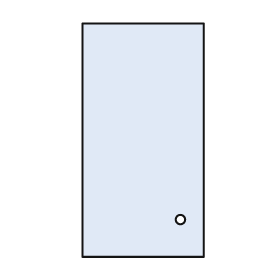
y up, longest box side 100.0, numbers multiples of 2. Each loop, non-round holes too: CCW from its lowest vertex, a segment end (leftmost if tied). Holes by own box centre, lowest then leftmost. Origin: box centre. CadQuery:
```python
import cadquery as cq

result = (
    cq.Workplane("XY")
    .moveTo(-26.0, -50.0)
    .lineTo(26.0, -50.0)
    .lineTo(26.0, 50.0)
    .lineTo(-26.0, 50.0)
    .close()
    .moveTo(16.0, -34.0)
    .circle(2.0)
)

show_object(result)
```